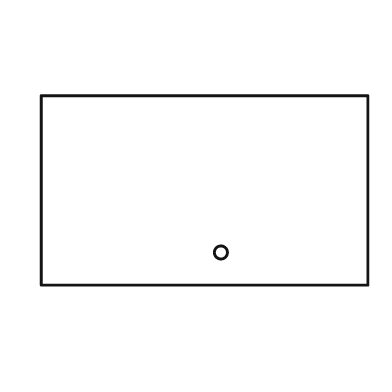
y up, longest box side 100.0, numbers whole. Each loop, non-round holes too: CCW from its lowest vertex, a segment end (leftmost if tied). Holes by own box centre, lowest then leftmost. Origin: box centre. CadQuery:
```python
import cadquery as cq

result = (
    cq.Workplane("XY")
    .moveTo(-50.0, -29.0)
    .lineTo(50.0, -29.0)
    .lineTo(50.0, 29.0)
    .lineTo(-50.0, 29.0)
    .close()
    .moveTo(5.0, -19.0)
    .circle(2.0)
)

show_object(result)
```